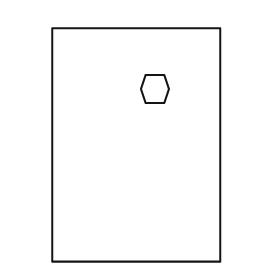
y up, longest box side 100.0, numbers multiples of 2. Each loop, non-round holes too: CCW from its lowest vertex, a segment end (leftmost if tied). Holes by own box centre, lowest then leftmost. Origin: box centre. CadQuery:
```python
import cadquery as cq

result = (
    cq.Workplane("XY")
    .moveTo(-36.0, -50.0)
    .lineTo(36.0, -50.0)
    .lineTo(36.0, 50.0)
    .lineTo(-36.0, 50.0)
    .close()
    .moveTo(4.0, 18.0)
    .lineTo(12.0, 18.0)
    .lineTo(14.0, 24.0)
    .lineTo(12.0, 30.0)
    .lineTo(4.0, 30.0)
    .lineTo(2.0, 24.0)
    .close()
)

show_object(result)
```